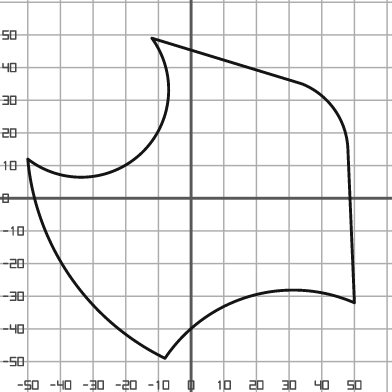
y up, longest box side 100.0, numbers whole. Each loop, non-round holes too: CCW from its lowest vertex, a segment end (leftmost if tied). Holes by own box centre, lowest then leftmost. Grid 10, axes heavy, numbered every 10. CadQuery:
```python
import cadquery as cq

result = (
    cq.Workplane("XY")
    .moveTo(-8.0, -49.0)
    .threePointArc((18.0, -30.0), (50.0, -32.0))
    .lineTo(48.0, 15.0)
    .threePointArc((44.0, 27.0), (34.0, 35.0))
    .lineTo(-12.0, 49.0)
    .threePointArc((-15.0, 14.0), (-50.0, 12.0))
    .threePointArc((-37.0, -24.0), (-8.0, -49.0))
    .close()
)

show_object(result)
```